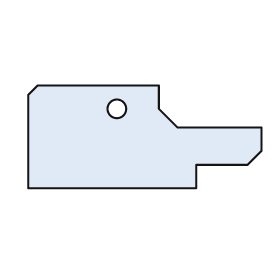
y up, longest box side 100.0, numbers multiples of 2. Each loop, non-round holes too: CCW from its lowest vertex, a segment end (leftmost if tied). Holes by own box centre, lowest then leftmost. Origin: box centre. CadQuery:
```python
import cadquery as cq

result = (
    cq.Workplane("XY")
    .moveTo(-50.0, -22.0)
    .lineTo(22.0, -22.0)
    .lineTo(22.0, -12.0)
    .lineTo(44.0, -12.0)
    .lineTo(50.0, -6.0)
    .lineTo(50.0, 4.0)
    .lineTo(14.0, 4.0)
    .lineTo(6.0, 12.0)
    .lineTo(6.0, 22.0)
    .lineTo(-46.0, 22.0)
    .lineTo(-50.0, 18.0)
    .close()
    .moveTo(-12.0, 12.0)
    .circle(4.0)
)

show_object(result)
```